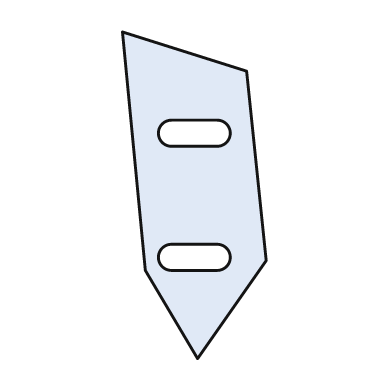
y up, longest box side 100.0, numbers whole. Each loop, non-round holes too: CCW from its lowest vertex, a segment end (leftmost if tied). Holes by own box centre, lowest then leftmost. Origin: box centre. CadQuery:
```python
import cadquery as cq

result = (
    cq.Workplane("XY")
    .moveTo(1.0, -50.0)
    .lineTo(22.0, -20.0)
    .lineTo(16.0, 38.0)
    .lineTo(-22.0, 50.0)
    .lineTo(-15.0, -23.0)
    .close()
    .moveTo(-7.0, -23.0)
    .lineTo(7.0, -23.0)
    .threePointArc((11.0, -19.0), (7.0, -15.0))
    .lineTo(-7.0, -15.0)
    .threePointArc((-11.0, -19.0), (-7.0, -23.0))
    .close()
    .moveTo(-7.0, 15.0)
    .lineTo(7.0, 15.0)
    .threePointArc((11.0, 19.0), (7.0, 23.0))
    .lineTo(-7.0, 23.0)
    .threePointArc((-11.0, 19.0), (-7.0, 15.0))
    .close()
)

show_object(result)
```